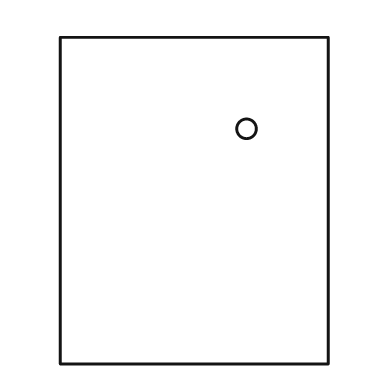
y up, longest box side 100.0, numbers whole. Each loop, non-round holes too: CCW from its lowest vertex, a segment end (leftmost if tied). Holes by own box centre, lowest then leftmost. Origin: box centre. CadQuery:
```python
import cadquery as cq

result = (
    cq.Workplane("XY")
    .moveTo(-41.0, -50.0)
    .lineTo(41.0, -50.0)
    .lineTo(41.0, 50.0)
    .lineTo(-41.0, 50.0)
    .close()
    .moveTo(16.0, 22.0)
    .circle(3.0)
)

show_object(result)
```